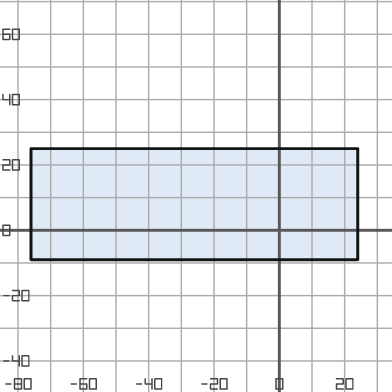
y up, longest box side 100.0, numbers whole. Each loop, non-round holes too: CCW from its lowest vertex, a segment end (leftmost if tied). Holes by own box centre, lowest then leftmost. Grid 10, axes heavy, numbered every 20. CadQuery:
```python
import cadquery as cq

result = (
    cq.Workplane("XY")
    .moveTo(-76.0, -9.0)
    .lineTo(24.0, -9.0)
    .lineTo(24.0, 25.0)
    .lineTo(-76.0, 25.0)
    .close()
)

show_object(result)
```